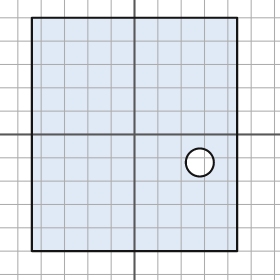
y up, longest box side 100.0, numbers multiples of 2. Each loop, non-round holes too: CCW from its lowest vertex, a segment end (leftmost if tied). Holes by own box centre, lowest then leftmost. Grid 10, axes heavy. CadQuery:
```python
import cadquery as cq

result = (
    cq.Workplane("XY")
    .moveTo(-44.0, -50.0)
    .lineTo(44.0, -50.0)
    .lineTo(44.0, 50.0)
    .lineTo(-44.0, 50.0)
    .close()
    .moveTo(28.0, -12.0)
    .circle(6.0)
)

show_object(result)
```